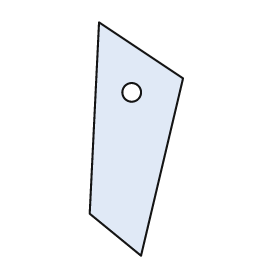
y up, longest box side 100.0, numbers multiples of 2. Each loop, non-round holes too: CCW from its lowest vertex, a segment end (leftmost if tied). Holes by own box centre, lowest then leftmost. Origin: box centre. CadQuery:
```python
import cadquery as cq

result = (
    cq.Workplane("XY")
    .moveTo(2.0, -50.0)
    .lineTo(20.0, 26.0)
    .lineTo(-16.0, 50.0)
    .lineTo(-20.0, -32.0)
    .close()
    .moveTo(-2.0, 20.0)
    .circle(4.0)
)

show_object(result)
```